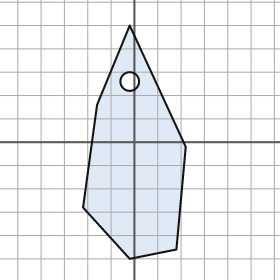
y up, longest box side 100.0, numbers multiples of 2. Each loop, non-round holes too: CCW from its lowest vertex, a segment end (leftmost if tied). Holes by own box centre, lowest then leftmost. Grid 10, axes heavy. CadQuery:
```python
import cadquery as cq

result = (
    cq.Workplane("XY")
    .moveTo(-2.0, -50.0)
    .lineTo(18.0, -46.0)
    .lineTo(22.0, -2.0)
    .lineTo(-2.0, 50.0)
    .lineTo(-16.0, 16.0)
    .lineTo(-22.0, -28.0)
    .close()
    .moveTo(-2.0, 26.0)
    .circle(4.0)
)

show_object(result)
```